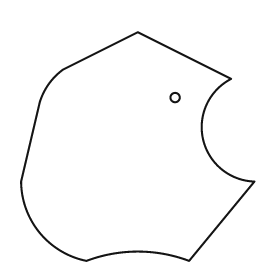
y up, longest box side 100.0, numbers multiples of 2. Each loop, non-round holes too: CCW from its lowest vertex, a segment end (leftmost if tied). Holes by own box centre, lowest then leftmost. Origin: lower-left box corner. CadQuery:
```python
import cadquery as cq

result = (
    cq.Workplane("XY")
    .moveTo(28.0, 0.0)
    .threePointArc((50.0, 4.0), (72.0, 0.0))
    .lineTo(100.0, 34.0)
    .threePointArc((78.0, 52.0), (90.0, 78.0))
    .lineTo(50.0, 98.0)
    .lineTo(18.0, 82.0)
    .threePointArc((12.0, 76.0), (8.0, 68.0))
    .lineTo(0.0, 34.0)
    .threePointArc((8.0, 12.0), (28.0, 0.0))
    .close()
    .moveTo(66.0, 70.0)
    .circle(2.0)
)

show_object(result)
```